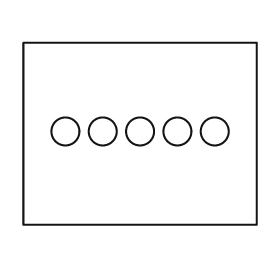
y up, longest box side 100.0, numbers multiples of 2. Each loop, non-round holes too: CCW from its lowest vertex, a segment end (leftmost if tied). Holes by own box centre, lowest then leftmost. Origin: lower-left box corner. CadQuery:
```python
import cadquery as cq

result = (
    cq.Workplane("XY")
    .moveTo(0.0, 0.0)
    .lineTo(100.0, 0.0)
    .lineTo(100.0, 78.0)
    .lineTo(0.0, 78.0)
    .close()
    .moveTo(18.0, 40.0)
    .circle(6.0)
    .moveTo(34.0, 40.0)
    .circle(6.0)
    .moveTo(50.0, 40.0)
    .circle(6.0)
    .moveTo(66.0, 40.0)
    .circle(6.0)
    .moveTo(82.0, 40.0)
    .circle(6.0)
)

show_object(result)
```